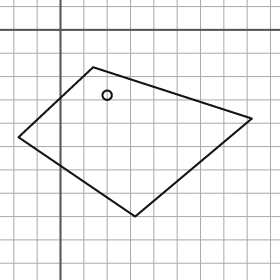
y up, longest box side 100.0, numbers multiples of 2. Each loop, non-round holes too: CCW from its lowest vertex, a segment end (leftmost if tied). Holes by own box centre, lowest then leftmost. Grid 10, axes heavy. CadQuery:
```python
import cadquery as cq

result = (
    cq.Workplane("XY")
    .moveTo(32.0, -80.0)
    .lineTo(82.0, -38.0)
    .lineTo(14.0, -16.0)
    .lineTo(-18.0, -46.0)
    .close()
    .moveTo(20.0, -28.0)
    .circle(2.0)
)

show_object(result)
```